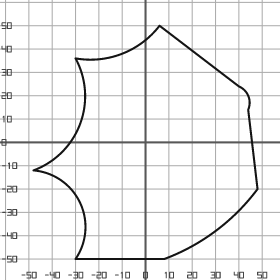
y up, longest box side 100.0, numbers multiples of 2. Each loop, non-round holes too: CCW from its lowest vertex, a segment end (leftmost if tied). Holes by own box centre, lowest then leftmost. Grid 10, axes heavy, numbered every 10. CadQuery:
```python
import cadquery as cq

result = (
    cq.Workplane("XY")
    .moveTo(-30.0, -50.0)
    .lineTo(8.0, -50.0)
    .threePointArc((30.0, -38.0), (48.0, -20.0))
    .lineTo(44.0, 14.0)
    .threePointArc((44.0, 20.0), (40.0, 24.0))
    .lineTo(6.0, 50.0)
    .threePointArc((-10.0, 38.0), (-30.0, 36.0))
    .threePointArc((-28.0, 8.0), (-48.0, -12.0))
    .threePointArc((-28.0, -26.0), (-30.0, -50.0))
    .close()
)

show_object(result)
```